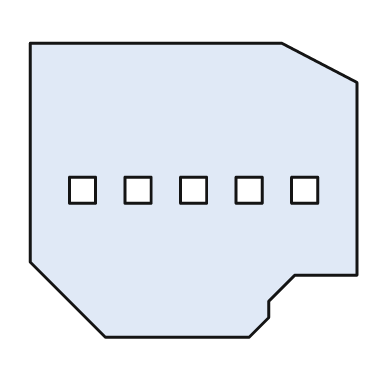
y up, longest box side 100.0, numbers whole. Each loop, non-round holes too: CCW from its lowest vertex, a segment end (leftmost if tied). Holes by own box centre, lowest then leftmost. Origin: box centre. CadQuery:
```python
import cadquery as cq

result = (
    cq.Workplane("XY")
    .moveTo(-27.0, -45.0)
    .lineTo(17.0, -45.0)
    .lineTo(23.0, -39.0)
    .lineTo(23.0, -34.0)
    .lineTo(31.0, -26.0)
    .lineTo(50.0, -26.0)
    .lineTo(50.0, 33.0)
    .lineTo(27.0, 45.0)
    .lineTo(-50.0, 45.0)
    .lineTo(-50.0, -22.0)
    .close()
    .moveTo(-38.0, -4.0)
    .lineTo(-30.0, -4.0)
    .lineTo(-30.0, 4.0)
    .lineTo(-38.0, 4.0)
    .close()
    .moveTo(-21.0, -4.0)
    .lineTo(-13.0, -4.0)
    .lineTo(-13.0, 4.0)
    .lineTo(-21.0, 4.0)
    .close()
    .moveTo(-4.0, -4.0)
    .lineTo(4.0, -4.0)
    .lineTo(4.0, 4.0)
    .lineTo(-4.0, 4.0)
    .close()
    .moveTo(13.0, -4.0)
    .lineTo(21.0, -4.0)
    .lineTo(21.0, 4.0)
    .lineTo(13.0, 4.0)
    .close()
    .moveTo(30.0, -4.0)
    .lineTo(38.0, -4.0)
    .lineTo(38.0, 4.0)
    .lineTo(30.0, 4.0)
    .close()
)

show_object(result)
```